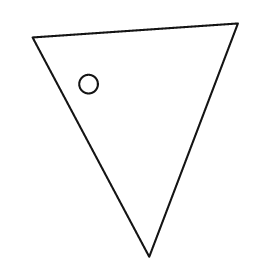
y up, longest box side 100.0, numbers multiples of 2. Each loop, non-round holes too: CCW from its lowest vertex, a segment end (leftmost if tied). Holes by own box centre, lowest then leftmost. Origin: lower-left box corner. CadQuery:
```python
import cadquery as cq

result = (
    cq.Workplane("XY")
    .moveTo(50.0, 0.0)
    .lineTo(88.0, 100.0)
    .lineTo(0.0, 94.0)
    .close()
    .moveTo(24.0, 74.0)
    .circle(4.0)
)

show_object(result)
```